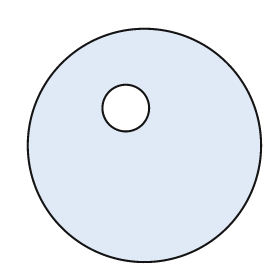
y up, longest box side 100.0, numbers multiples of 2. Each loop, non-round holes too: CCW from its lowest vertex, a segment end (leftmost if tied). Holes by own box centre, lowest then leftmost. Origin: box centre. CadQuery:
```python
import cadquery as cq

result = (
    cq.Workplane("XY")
    .moveTo(0.0, 0.0)
    .circle(50.0)
    .moveTo(-8.0, 16.0)
    .circle(10.0)
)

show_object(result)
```